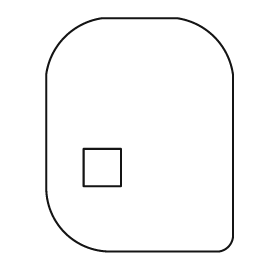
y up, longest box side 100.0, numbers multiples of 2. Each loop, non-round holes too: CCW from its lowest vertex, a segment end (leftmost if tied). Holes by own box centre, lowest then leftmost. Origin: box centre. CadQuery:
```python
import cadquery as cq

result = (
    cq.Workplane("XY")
    .moveTo(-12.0, -50.0)
    .lineTo(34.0, -50.0)
    .threePointArc((38.0, -48.0), (40.0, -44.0))
    .lineTo(40.0, 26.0)
    .threePointArc((32.0, 42.0), (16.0, 50.0))
    .lineTo(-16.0, 50.0)
    .threePointArc((-32.0, 42.0), (-40.0, 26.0))
    .lineTo(-40.0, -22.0)
    .threePointArc((-32.0, -42.0), (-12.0, -50.0))
    .close()
    .moveTo(-24.0, -22.0)
    .lineTo(-8.0, -22.0)
    .lineTo(-8.0, -6.0)
    .lineTo(-24.0, -6.0)
    .close()
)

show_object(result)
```